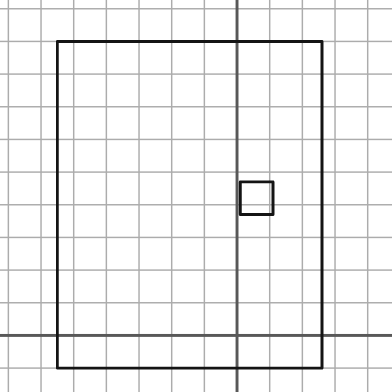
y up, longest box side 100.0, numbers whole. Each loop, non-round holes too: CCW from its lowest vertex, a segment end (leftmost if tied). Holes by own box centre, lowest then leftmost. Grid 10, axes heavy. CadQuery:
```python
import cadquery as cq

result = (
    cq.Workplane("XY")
    .moveTo(-55.0, -10.0)
    .lineTo(26.0, -10.0)
    .lineTo(26.0, 90.0)
    .lineTo(-55.0, 90.0)
    .close()
    .moveTo(1.0, 37.0)
    .lineTo(11.0, 37.0)
    .lineTo(11.0, 47.0)
    .lineTo(1.0, 47.0)
    .close()
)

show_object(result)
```